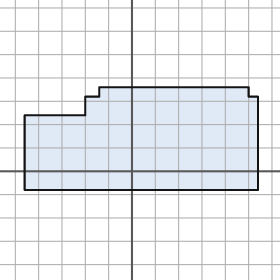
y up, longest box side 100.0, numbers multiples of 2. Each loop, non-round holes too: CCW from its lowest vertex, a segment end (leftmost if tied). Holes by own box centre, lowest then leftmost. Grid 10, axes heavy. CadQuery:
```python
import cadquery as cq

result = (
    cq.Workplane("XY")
    .moveTo(-46.0, -8.0)
    .lineTo(54.0, -8.0)
    .lineTo(54.0, 32.0)
    .lineTo(50.0, 32.0)
    .lineTo(50.0, 36.0)
    .lineTo(-14.0, 36.0)
    .lineTo(-14.0, 32.0)
    .lineTo(-20.0, 32.0)
    .lineTo(-20.0, 24.0)
    .lineTo(-46.0, 24.0)
    .close()
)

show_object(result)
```